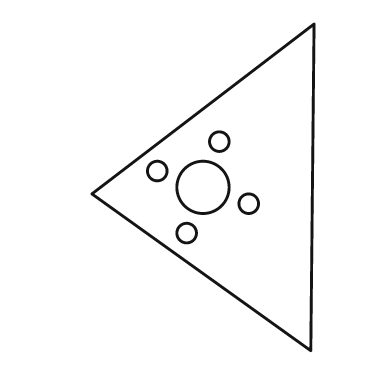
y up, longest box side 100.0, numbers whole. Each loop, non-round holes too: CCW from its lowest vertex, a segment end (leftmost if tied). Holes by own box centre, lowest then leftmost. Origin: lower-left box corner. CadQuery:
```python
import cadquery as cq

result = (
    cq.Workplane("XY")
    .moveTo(67.0, 0.0)
    .lineTo(68.0, 100.0)
    .lineTo(0.0, 48.0)
    .close()
    .moveTo(29.0, 36.0)
    .circle(3.0)
    .moveTo(48.0, 45.0)
    .circle(3.0)
    .moveTo(34.0, 50.0)
    .circle(8.0)
    .moveTo(20.0, 55.0)
    .circle(3.0)
    .moveTo(39.0, 64.0)
    .circle(3.0)
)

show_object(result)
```